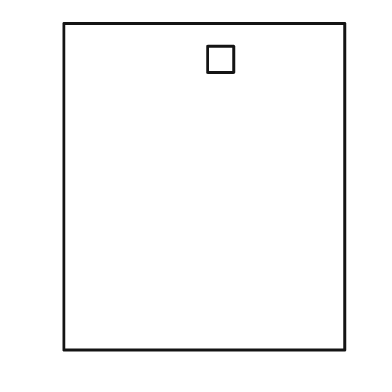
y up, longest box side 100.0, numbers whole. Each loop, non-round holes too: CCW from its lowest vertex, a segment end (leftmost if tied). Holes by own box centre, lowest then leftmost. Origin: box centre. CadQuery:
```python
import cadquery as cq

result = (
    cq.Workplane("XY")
    .moveTo(-43.0, -50.0)
    .lineTo(43.0, -50.0)
    .lineTo(43.0, 50.0)
    .lineTo(-43.0, 50.0)
    .close()
    .moveTo(1.0, 35.0)
    .lineTo(9.0, 35.0)
    .lineTo(9.0, 43.0)
    .lineTo(1.0, 43.0)
    .close()
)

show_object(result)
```